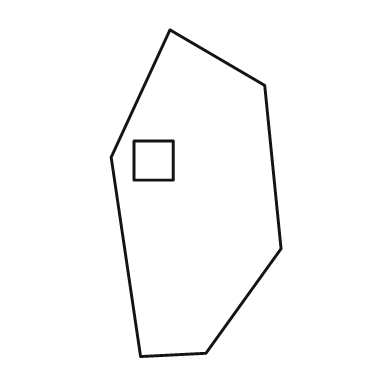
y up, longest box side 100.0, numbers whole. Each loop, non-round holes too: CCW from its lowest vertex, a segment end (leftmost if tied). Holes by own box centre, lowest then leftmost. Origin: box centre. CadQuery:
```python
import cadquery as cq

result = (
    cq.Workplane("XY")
    .moveTo(-17.0, -50.0)
    .lineTo(3.0, -49.0)
    .lineTo(26.0, -17.0)
    .lineTo(21.0, 33.0)
    .lineTo(-8.0, 50.0)
    .lineTo(-26.0, 11.0)
    .close()
    .moveTo(-19.0, 4.0)
    .lineTo(-7.0, 4.0)
    .lineTo(-7.0, 16.0)
    .lineTo(-19.0, 16.0)
    .close()
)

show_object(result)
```